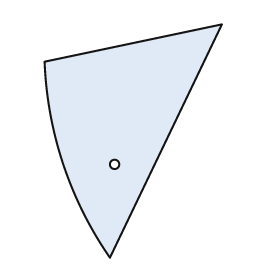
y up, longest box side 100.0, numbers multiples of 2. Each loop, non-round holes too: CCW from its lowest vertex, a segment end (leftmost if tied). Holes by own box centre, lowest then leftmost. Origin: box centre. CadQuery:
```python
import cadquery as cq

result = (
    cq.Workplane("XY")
    .moveTo(-10.0, -50.0)
    .lineTo(38.0, 50.0)
    .lineTo(-38.0, 34.0)
    .threePointArc((-30.0, -10.0), (-10.0, -50.0))
    .close()
    .moveTo(-8.0, -10.0)
    .circle(2.0)
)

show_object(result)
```